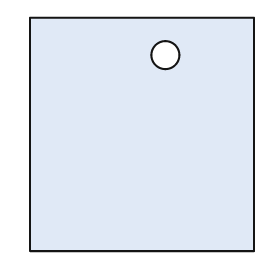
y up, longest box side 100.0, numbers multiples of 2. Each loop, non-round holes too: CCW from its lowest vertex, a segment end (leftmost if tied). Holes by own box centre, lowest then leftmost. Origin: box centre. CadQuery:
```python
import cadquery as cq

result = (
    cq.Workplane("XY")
    .moveTo(-48.0, -50.0)
    .lineTo(48.0, -50.0)
    .lineTo(48.0, 50.0)
    .lineTo(-48.0, 50.0)
    .close()
    .moveTo(10.0, 34.0)
    .circle(6.0)
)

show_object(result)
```